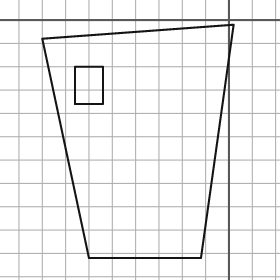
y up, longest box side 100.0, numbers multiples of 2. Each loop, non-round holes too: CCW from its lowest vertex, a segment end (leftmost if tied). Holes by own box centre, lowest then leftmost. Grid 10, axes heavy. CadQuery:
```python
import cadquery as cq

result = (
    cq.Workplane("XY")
    .moveTo(-60.0, -102.0)
    .lineTo(-12.0, -102.0)
    .lineTo(2.0, -2.0)
    .lineTo(-80.0, -8.0)
    .close()
    .moveTo(-66.0, -36.0)
    .lineTo(-54.0, -36.0)
    .lineTo(-54.0, -20.0)
    .lineTo(-66.0, -20.0)
    .close()
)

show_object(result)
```